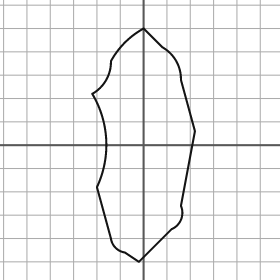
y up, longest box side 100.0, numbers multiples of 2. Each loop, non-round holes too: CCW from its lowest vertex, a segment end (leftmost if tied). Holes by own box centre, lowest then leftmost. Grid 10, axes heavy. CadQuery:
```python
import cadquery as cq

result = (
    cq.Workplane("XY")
    .moveTo(-2.0, -50.0)
    .lineTo(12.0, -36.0)
    .threePointArc((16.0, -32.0), (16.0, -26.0))
    .lineTo(22.0, 6.0)
    .lineTo(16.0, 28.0)
    .threePointArc((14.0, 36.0), (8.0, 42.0))
    .lineTo(0.0, 50.0)
    .threePointArc((-8.0, 44.0), (-14.0, 36.0))
    .threePointArc((-16.0, 28.0), (-22.0, 22.0))
    .threePointArc((-16.0, 2.0), (-20.0, -18.0))
    .lineTo(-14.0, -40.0)
    .threePointArc((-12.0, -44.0), (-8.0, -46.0))
    .close()
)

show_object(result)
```